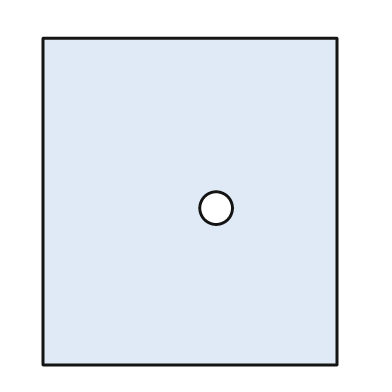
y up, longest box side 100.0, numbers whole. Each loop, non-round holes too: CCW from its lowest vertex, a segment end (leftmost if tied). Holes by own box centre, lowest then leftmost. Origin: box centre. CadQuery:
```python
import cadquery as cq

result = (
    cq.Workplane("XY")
    .moveTo(-45.0, -50.0)
    .lineTo(45.0, -50.0)
    .lineTo(45.0, 50.0)
    .lineTo(-45.0, 50.0)
    .close()
    .moveTo(8.0, -2.0)
    .circle(5.0)
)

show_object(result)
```